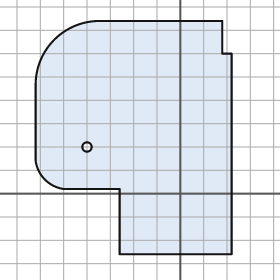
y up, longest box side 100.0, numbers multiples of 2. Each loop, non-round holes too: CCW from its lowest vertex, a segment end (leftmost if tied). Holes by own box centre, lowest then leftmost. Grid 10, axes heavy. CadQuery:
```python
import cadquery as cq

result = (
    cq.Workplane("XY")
    .moveTo(-26.0, -26.0)
    .lineTo(22.0, -26.0)
    .lineTo(22.0, 60.0)
    .lineTo(18.0, 60.0)
    .lineTo(18.0, 74.0)
    .lineTo(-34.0, 74.0)
    .threePointArc((-54.0, 66.0), (-62.0, 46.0))
    .lineTo(-62.0, 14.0)
    .threePointArc((-58.0, 6.0), (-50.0, 2.0))
    .lineTo(-26.0, 2.0)
    .close()
    .moveTo(-40.0, 20.0)
    .circle(2.0)
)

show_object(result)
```